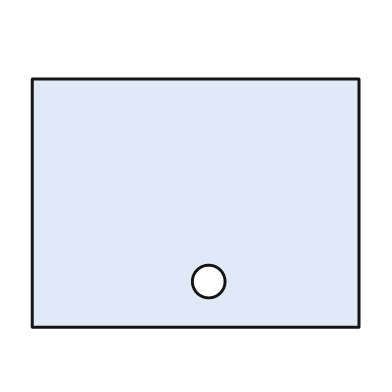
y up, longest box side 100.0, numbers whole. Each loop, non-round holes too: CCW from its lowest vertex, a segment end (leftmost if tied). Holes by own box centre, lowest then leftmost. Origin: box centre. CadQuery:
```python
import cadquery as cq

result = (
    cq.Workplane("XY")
    .moveTo(-50.0, -38.0)
    .lineTo(50.0, -38.0)
    .lineTo(50.0, 38.0)
    .lineTo(-50.0, 38.0)
    .close()
    .moveTo(4.0, -24.0)
    .circle(5.0)
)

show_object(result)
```